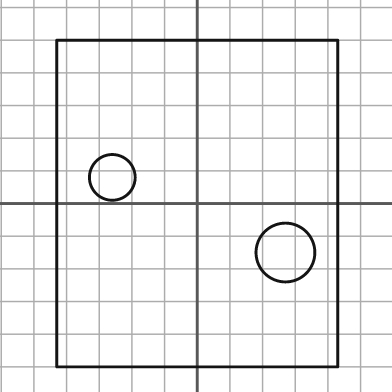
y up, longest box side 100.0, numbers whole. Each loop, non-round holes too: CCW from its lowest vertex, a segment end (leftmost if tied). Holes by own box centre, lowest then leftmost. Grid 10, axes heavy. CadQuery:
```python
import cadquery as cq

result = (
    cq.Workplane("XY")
    .moveTo(-43.0, -50.0)
    .lineTo(43.0, -50.0)
    .lineTo(43.0, 50.0)
    .lineTo(-43.0, 50.0)
    .close()
    .moveTo(27.0, -15.0)
    .circle(9.0)
    .moveTo(-26.0, 8.0)
    .circle(7.0)
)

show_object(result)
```